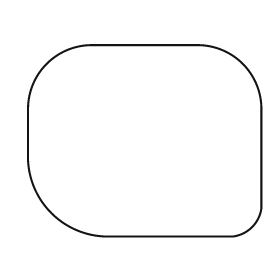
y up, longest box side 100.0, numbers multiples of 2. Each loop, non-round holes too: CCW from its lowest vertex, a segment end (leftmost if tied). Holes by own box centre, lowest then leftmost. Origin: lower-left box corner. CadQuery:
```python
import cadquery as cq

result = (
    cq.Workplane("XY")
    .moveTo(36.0, 0.0)
    .lineTo(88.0, 0.0)
    .threePointArc((96.0, 4.0), (100.0, 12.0))
    .lineTo(100.0, 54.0)
    .threePointArc((92.0, 74.0), (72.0, 82.0))
    .lineTo(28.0, 82.0)
    .threePointArc((8.0, 74.0), (0.0, 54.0))
    .lineTo(0.0, 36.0)
    .threePointArc((10.0, 10.0), (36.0, 0.0))
    .close()
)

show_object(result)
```